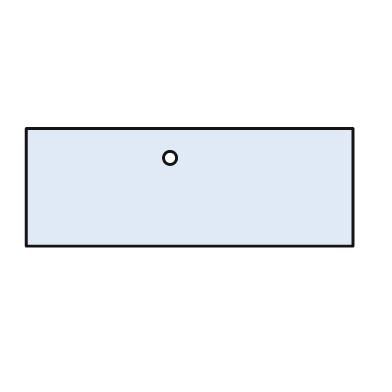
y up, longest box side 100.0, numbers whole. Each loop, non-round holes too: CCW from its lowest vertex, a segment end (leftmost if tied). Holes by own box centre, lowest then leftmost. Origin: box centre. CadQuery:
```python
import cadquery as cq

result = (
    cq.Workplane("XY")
    .moveTo(-50.0, -18.0)
    .lineTo(50.0, -18.0)
    .lineTo(50.0, 18.0)
    .lineTo(-50.0, 18.0)
    .close()
    .moveTo(-6.0, 9.0)
    .circle(2.0)
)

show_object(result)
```